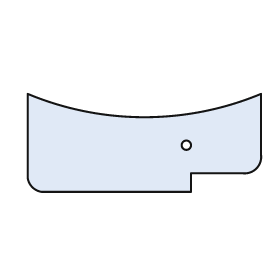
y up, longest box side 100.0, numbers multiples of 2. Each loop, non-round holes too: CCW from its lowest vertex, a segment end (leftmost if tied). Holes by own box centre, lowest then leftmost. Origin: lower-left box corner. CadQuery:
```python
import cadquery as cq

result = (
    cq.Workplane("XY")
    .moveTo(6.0, 0.0)
    .lineTo(70.0, 0.0)
    .lineTo(70.0, 8.0)
    .lineTo(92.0, 8.0)
    .threePointArc((98.0, 10.0), (100.0, 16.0))
    .lineTo(100.0, 42.0)
    .threePointArc((50.0, 32.0), (0.0, 42.0))
    .lineTo(0.0, 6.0)
    .threePointArc((2.0, 2.0), (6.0, 0.0))
    .close()
    .moveTo(68.0, 20.0)
    .circle(2.0)
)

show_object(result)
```